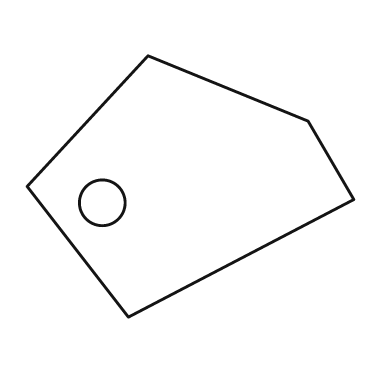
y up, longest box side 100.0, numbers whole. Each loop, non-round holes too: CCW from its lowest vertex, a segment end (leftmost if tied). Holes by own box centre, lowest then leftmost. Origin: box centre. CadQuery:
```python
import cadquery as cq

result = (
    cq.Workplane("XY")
    .moveTo(-19.0, -40.0)
    .lineTo(50.0, -4.0)
    .lineTo(36.0, 20.0)
    .lineTo(-13.0, 40.0)
    .lineTo(-50.0, 0.0)
    .close()
    .moveTo(-27.0, -5.0)
    .circle(7.0)
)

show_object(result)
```